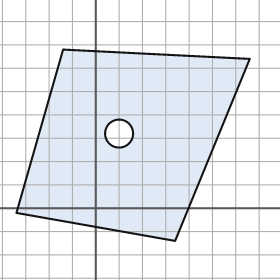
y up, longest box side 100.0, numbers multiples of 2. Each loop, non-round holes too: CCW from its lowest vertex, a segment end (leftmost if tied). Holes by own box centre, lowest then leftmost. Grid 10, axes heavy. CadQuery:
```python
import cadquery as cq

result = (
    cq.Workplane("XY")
    .moveTo(34.0, -14.0)
    .lineTo(66.0, 64.0)
    .lineTo(-14.0, 68.0)
    .lineTo(-34.0, -2.0)
    .close()
    .moveTo(10.0, 32.0)
    .circle(6.0)
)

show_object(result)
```